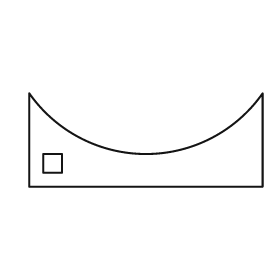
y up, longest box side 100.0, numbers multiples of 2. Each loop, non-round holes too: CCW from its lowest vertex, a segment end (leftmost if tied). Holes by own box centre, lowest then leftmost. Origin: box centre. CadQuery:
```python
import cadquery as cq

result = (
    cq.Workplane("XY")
    .moveTo(-50.0, -20.0)
    .lineTo(50.0, -20.0)
    .lineTo(50.0, 20.0)
    .threePointArc((0.0, -6.0), (-50.0, 20.0))
    .close()
    .moveTo(-44.0, -14.0)
    .lineTo(-36.0, -14.0)
    .lineTo(-36.0, -6.0)
    .lineTo(-44.0, -6.0)
    .close()
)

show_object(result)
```